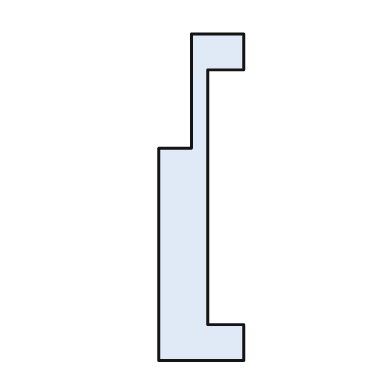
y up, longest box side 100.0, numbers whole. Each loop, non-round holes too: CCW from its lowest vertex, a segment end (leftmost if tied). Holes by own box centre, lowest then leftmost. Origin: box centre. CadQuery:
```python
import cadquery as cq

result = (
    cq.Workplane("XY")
    .moveTo(-13.0, -50.0)
    .lineTo(13.0, -50.0)
    .lineTo(13.0, -39.0)
    .lineTo(2.0, -39.0)
    .lineTo(2.0, 39.0)
    .lineTo(13.0, 39.0)
    .lineTo(13.0, 50.0)
    .lineTo(-3.0, 50.0)
    .lineTo(-3.0, 15.0)
    .lineTo(-13.0, 15.0)
    .close()
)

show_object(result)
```